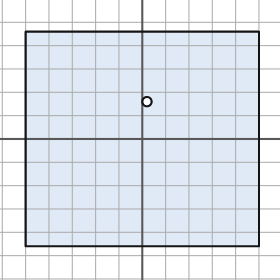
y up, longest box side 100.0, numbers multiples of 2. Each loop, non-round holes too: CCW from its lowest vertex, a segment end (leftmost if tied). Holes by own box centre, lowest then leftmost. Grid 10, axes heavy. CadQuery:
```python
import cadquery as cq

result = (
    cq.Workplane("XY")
    .moveTo(-50.0, -46.0)
    .lineTo(50.0, -46.0)
    .lineTo(50.0, 46.0)
    .lineTo(-50.0, 46.0)
    .close()
    .moveTo(2.0, 16.0)
    .circle(2.0)
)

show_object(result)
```